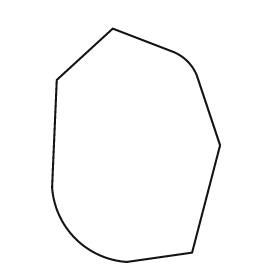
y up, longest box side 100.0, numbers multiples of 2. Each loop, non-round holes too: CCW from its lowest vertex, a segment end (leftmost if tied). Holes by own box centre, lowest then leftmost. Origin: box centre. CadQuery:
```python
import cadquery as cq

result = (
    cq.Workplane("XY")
    .moveTo(-4.0, -50.0)
    .lineTo(24.0, -46.0)
    .lineTo(36.0, 0.0)
    .lineTo(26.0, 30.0)
    .threePointArc((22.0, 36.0), (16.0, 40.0))
    .lineTo(-10.0, 50.0)
    .lineTo(-34.0, 28.0)
    .lineTo(-36.0, -18.0)
    .threePointArc((-26.0, -40.0), (-4.0, -50.0))
    .close()
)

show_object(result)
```